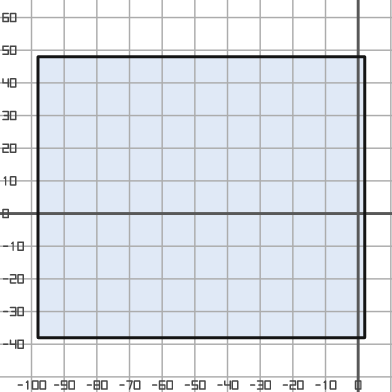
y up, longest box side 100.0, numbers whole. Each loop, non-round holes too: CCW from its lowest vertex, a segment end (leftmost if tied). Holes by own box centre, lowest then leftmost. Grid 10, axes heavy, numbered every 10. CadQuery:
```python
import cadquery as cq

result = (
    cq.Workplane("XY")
    .moveTo(-98.0, -38.0)
    .lineTo(2.0, -38.0)
    .lineTo(2.0, 48.0)
    .lineTo(-98.0, 48.0)
    .close()
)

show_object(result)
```